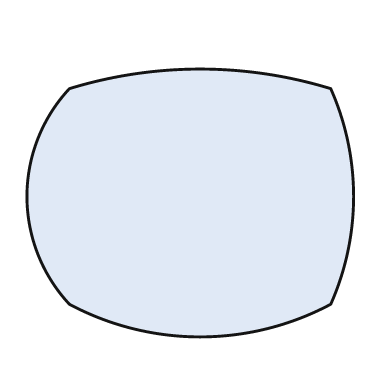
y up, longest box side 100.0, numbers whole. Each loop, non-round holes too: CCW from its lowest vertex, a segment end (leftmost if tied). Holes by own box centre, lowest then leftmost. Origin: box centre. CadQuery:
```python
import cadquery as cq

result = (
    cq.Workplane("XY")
    .moveTo(-37.0, -31.0)
    .threePointArc((3.0, -41.0), (43.0, -31.0))
    .threePointArc((50.0, 2.0), (43.0, 35.0))
    .threePointArc((3.0, 41.0), (-37.0, 35.0))
    .threePointArc((-50.0, 2.0), (-37.0, -31.0))
    .close()
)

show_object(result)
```